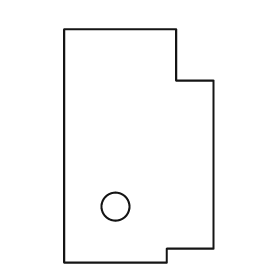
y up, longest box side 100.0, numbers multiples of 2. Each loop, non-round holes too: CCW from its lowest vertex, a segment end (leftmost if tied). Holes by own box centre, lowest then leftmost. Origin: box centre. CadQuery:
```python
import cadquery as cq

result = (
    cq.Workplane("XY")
    .moveTo(-32.0, -50.0)
    .lineTo(12.0, -50.0)
    .lineTo(12.0, -44.0)
    .lineTo(32.0, -44.0)
    .lineTo(32.0, 28.0)
    .lineTo(16.0, 28.0)
    .lineTo(16.0, 50.0)
    .lineTo(-32.0, 50.0)
    .close()
    .moveTo(-10.0, -26.0)
    .circle(6.0)
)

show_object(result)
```